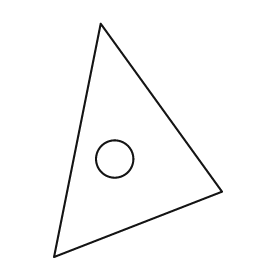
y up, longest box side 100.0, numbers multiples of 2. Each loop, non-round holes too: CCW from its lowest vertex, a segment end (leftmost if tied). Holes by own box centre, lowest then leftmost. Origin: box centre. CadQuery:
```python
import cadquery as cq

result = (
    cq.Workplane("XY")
    .moveTo(-36.0, -50.0)
    .lineTo(36.0, -22.0)
    .lineTo(-16.0, 50.0)
    .close()
    .moveTo(-10.0, -8.0)
    .circle(8.0)
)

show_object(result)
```